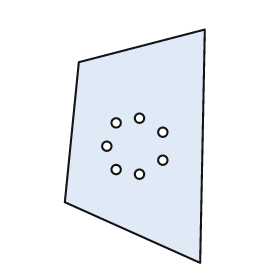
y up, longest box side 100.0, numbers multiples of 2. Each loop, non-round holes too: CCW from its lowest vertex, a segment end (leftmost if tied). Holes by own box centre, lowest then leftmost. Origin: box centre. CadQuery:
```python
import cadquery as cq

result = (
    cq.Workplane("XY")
    .moveTo(28.0, -50.0)
    .lineTo(30.0, 50.0)
    .lineTo(-24.0, 36.0)
    .lineTo(-30.0, -24.0)
    .close()
    .moveTo(2.0, -12.0)
    .circle(2.0)
    .moveTo(-8.0, -10.0)
    .circle(2.0)
    .moveTo(12.0, -6.0)
    .circle(2.0)
    .moveTo(-12.0, 0.0)
    .circle(2.0)
    .moveTo(12.0, 6.0)
    .circle(2.0)
    .moveTo(-8.0, 10.0)
    .circle(2.0)
    .moveTo(2.0, 12.0)
    .circle(2.0)
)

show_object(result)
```